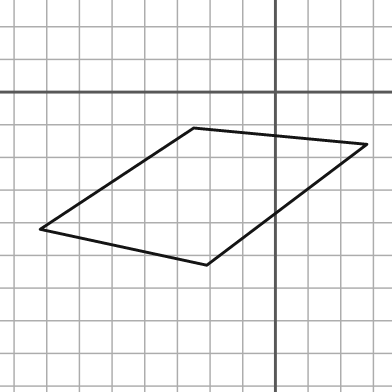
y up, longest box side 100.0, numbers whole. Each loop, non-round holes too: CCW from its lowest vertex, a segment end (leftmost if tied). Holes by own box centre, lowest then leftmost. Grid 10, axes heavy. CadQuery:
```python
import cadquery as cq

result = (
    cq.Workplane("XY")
    .moveTo(-21.0, -53.0)
    .lineTo(28.0, -16.0)
    .lineTo(-25.0, -11.0)
    .lineTo(-72.0, -42.0)
    .close()
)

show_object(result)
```